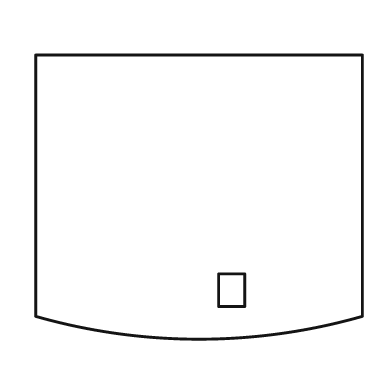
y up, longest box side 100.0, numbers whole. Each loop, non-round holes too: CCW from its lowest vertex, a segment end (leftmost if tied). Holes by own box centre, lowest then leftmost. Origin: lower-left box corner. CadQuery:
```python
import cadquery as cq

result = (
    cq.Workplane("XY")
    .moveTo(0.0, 7.0)
    .threePointArc((50.0, 0.0), (100.0, 7.0))
    .lineTo(100.0, 87.0)
    .lineTo(0.0, 87.0)
    .close()
    .moveTo(56.0, 10.0)
    .lineTo(64.0, 10.0)
    .lineTo(64.0, 20.0)
    .lineTo(56.0, 20.0)
    .close()
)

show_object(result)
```